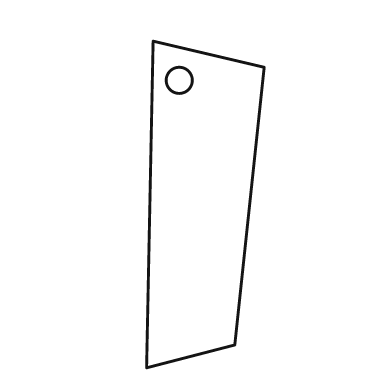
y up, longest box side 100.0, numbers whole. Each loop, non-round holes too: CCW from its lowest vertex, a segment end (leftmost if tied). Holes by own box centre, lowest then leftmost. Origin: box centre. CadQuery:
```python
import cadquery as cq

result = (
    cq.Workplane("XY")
    .moveTo(-18.0, -50.0)
    .lineTo(9.0, -43.0)
    .lineTo(18.0, 42.0)
    .lineTo(-16.0, 50.0)
    .close()
    .moveTo(-8.0, 38.0)
    .circle(4.0)
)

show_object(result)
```